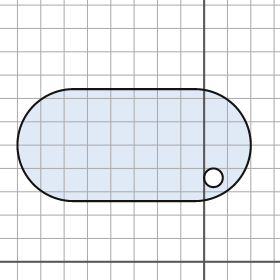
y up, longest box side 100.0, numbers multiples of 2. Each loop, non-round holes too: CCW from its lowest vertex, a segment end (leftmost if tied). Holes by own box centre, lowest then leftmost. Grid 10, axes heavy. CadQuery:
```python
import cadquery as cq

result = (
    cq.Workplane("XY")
    .moveTo(-56.0, 26.0)
    .lineTo(-4.0, 26.0)
    .threePointArc((20.0, 50.0), (-4.0, 74.0))
    .lineTo(-56.0, 74.0)
    .threePointArc((-80.0, 50.0), (-56.0, 26.0))
    .close()
    .moveTo(4.0, 36.0)
    .circle(4.0)
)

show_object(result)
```